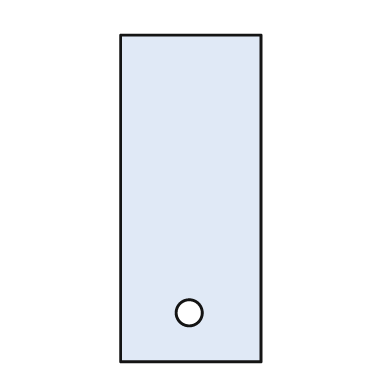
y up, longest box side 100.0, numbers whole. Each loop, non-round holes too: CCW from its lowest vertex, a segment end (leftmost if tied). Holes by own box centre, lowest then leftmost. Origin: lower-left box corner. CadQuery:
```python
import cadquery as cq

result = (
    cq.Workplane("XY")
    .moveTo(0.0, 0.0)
    .lineTo(43.0, 0.0)
    .lineTo(43.0, 100.0)
    .lineTo(0.0, 100.0)
    .close()
    .moveTo(21.0, 15.0)
    .circle(4.0)
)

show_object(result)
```